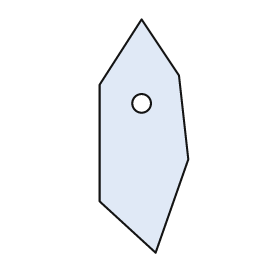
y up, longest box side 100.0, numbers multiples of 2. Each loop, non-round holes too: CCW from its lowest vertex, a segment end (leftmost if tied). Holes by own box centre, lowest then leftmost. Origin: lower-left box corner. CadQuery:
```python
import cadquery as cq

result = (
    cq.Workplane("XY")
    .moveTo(24.0, 0.0)
    .lineTo(38.0, 40.0)
    .lineTo(34.0, 76.0)
    .lineTo(18.0, 100.0)
    .lineTo(0.0, 72.0)
    .lineTo(0.0, 22.0)
    .close()
    .moveTo(18.0, 64.0)
    .circle(4.0)
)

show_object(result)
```